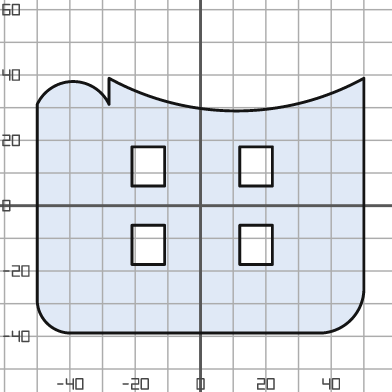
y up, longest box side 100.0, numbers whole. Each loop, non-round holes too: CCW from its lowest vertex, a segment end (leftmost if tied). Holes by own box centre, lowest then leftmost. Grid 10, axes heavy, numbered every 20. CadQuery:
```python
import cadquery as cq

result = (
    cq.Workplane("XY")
    .moveTo(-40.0, -39.0)
    .lineTo(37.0, -39.0)
    .threePointArc((46.0, -35.0), (50.0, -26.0))
    .lineTo(50.0, 39.0)
    .threePointArc((11.0, 29.0), (-28.0, 39.0))
    .lineTo(-28.0, 31.0)
    .threePointArc((-39.0, 38.0), (-50.0, 31.0))
    .lineTo(-50.0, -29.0)
    .threePointArc((-47.0, -36.0), (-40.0, -39.0))
    .close()
    .moveTo(-21.0, -18.0)
    .lineTo(-11.0, -18.0)
    .lineTo(-11.0, -6.0)
    .lineTo(-21.0, -6.0)
    .close()
    .moveTo(12.0, -18.0)
    .lineTo(22.0, -18.0)
    .lineTo(22.0, -6.0)
    .lineTo(12.0, -6.0)
    .close()
    .moveTo(-21.0, 6.0)
    .lineTo(-11.0, 6.0)
    .lineTo(-11.0, 18.0)
    .lineTo(-21.0, 18.0)
    .close()
    .moveTo(12.0, 6.0)
    .lineTo(22.0, 6.0)
    .lineTo(22.0, 18.0)
    .lineTo(12.0, 18.0)
    .close()
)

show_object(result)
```